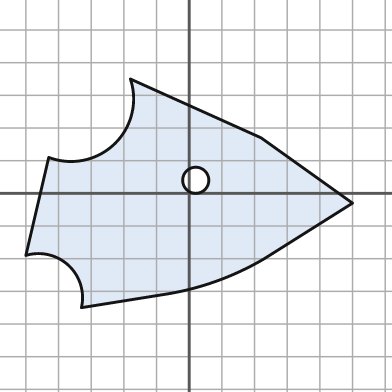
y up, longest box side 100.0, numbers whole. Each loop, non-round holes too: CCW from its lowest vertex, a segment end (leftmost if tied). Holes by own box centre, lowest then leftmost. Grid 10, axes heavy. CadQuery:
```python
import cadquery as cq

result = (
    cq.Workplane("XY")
    .moveTo(-33.0, -35.0)
    .lineTo(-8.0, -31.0)
    .threePointArc((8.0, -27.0), (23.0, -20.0))
    .lineTo(50.0, -3.0)
    .lineTo(22.0, 17.0)
    .lineTo(-18.0, 35.0)
    .threePointArc((-23.0, 15.0), (-43.0, 11.0))
    .lineTo(-50.0, -19.0)
    .threePointArc((-37.0, -22.0), (-33.0, -35.0))
    .close()
    .moveTo(2.0, 4.0)
    .circle(4.0)
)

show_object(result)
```